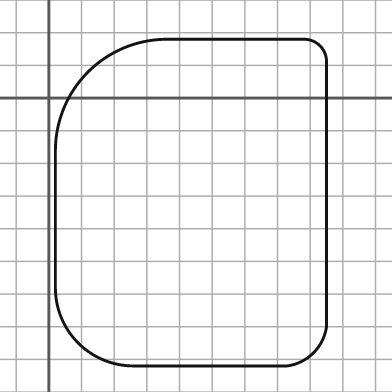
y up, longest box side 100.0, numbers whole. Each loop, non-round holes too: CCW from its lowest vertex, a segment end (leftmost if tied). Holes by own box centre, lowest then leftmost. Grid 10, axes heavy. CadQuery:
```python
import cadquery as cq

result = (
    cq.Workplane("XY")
    .moveTo(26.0, -82.0)
    .lineTo(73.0, -82.0)
    .threePointArc((81.0, -78.0), (85.0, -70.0))
    .lineTo(85.0, 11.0)
    .threePointArc((83.0, 16.0), (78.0, 18.0))
    .lineTo(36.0, 18.0)
    .threePointArc((12.0, 8.0), (2.0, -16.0))
    .lineTo(2.0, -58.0)
    .threePointArc((9.0, -75.0), (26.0, -82.0))
    .close()
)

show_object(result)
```